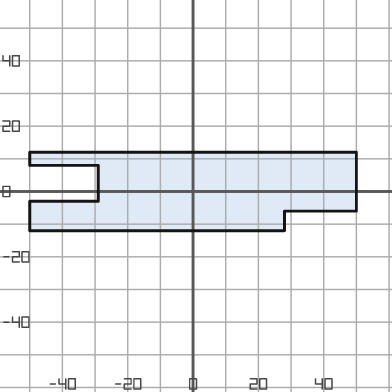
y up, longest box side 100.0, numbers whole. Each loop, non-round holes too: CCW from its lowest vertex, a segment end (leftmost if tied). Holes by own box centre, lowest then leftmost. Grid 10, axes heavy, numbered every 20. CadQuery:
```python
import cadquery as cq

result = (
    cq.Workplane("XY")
    .moveTo(-50.0, -12.0)
    .lineTo(28.0, -12.0)
    .lineTo(28.0, -6.0)
    .lineTo(50.0, -6.0)
    .lineTo(50.0, 12.0)
    .lineTo(-50.0, 12.0)
    .lineTo(-50.0, 8.0)
    .lineTo(-29.0, 8.0)
    .lineTo(-29.0, -3.0)
    .lineTo(-50.0, -3.0)
    .close()
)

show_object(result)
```